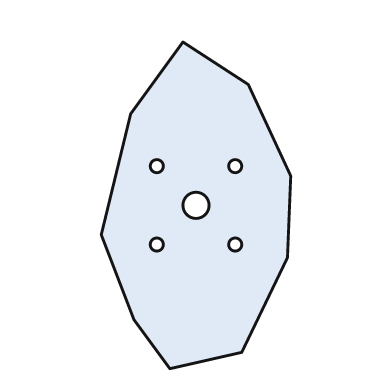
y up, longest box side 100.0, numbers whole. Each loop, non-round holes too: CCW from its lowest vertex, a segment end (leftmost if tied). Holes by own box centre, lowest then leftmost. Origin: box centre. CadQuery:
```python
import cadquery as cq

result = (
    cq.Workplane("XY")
    .moveTo(-8.0, -50.0)
    .lineTo(14.0, -45.0)
    .lineTo(28.0, -16.0)
    .lineTo(29.0, 9.0)
    .lineTo(16.0, 37.0)
    .lineTo(-4.0, 50.0)
    .lineTo(-20.0, 28.0)
    .lineTo(-29.0, -9.0)
    .lineTo(-19.0, -35.0)
    .close()
    .moveTo(-12.0, -12.0)
    .circle(2.0)
    .moveTo(12.0, -12.0)
    .circle(2.0)
    .moveTo(0.0, 0.0)
    .circle(4.0)
    .moveTo(-12.0, 12.0)
    .circle(2.0)
    .moveTo(12.0, 12.0)
    .circle(2.0)
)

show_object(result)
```